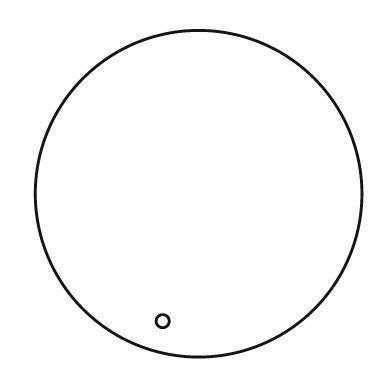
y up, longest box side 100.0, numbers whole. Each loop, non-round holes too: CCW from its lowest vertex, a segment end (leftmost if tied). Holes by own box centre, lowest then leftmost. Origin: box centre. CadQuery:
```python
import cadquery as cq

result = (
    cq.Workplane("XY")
    .moveTo(0.0, 0.0)
    .circle(50.0)
    .moveTo(-11.0, -39.0)
    .circle(2.0)
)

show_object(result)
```